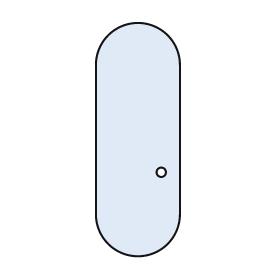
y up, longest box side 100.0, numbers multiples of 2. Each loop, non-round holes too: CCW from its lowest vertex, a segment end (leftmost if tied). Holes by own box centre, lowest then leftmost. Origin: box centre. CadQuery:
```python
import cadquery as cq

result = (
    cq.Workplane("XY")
    .moveTo(-18.0, -32.0)
    .threePointArc((0.0, -50.0), (18.0, -32.0))
    .lineTo(18.0, 32.0)
    .threePointArc((0.0, 50.0), (-18.0, 32.0))
    .close()
    .moveTo(10.0, -14.0)
    .circle(2.0)
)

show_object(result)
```